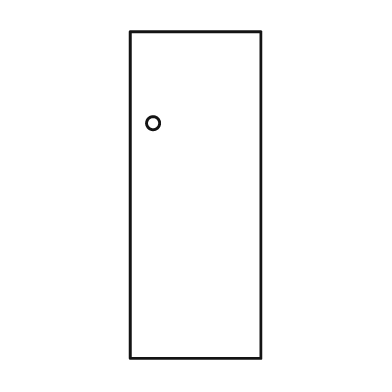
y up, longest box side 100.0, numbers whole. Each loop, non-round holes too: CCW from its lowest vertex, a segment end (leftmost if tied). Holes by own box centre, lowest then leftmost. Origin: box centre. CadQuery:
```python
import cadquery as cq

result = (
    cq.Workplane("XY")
    .moveTo(-20.0, -50.0)
    .lineTo(20.0, -50.0)
    .lineTo(20.0, 50.0)
    .lineTo(-20.0, 50.0)
    .close()
    .moveTo(-13.0, 22.0)
    .circle(2.0)
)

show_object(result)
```